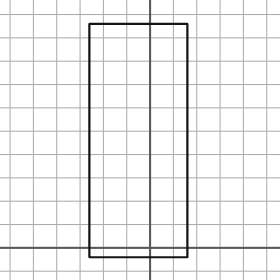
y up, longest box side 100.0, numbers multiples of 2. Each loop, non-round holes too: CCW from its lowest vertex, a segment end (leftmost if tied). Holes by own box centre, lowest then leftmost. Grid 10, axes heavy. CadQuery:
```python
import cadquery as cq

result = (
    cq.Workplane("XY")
    .moveTo(-26.0, -4.0)
    .lineTo(16.0, -4.0)
    .lineTo(16.0, 96.0)
    .lineTo(-26.0, 96.0)
    .close()
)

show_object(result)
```